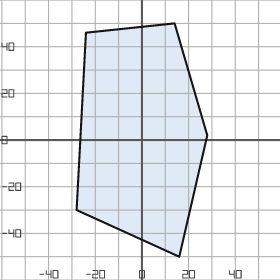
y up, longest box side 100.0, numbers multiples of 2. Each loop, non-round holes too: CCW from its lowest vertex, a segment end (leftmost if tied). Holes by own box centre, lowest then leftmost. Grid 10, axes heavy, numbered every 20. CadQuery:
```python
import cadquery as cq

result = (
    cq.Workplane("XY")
    .moveTo(16.0, -50.0)
    .lineTo(28.0, 2.0)
    .lineTo(14.0, 50.0)
    .lineTo(-24.0, 46.0)
    .lineTo(-28.0, -30.0)
    .close()
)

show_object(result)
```